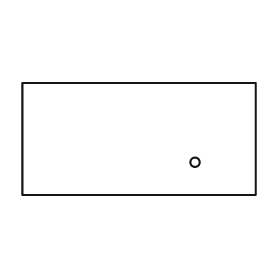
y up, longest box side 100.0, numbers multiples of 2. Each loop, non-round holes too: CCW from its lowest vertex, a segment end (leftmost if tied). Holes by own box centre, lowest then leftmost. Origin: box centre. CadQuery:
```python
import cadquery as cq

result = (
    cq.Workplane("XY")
    .moveTo(-50.0, -24.0)
    .lineTo(50.0, -24.0)
    .lineTo(50.0, 24.0)
    .lineTo(-50.0, 24.0)
    .close()
    .moveTo(24.0, -10.0)
    .circle(2.0)
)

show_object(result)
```